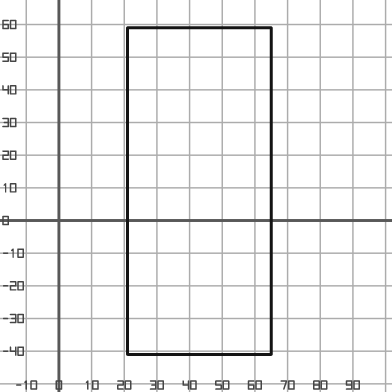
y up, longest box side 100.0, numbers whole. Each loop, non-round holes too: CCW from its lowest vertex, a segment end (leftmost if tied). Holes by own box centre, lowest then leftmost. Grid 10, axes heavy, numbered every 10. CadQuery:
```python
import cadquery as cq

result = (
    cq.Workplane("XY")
    .moveTo(21.0, -41.0)
    .lineTo(65.0, -41.0)
    .lineTo(65.0, 59.0)
    .lineTo(21.0, 59.0)
    .close()
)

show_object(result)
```